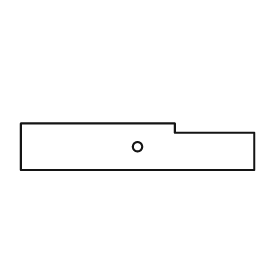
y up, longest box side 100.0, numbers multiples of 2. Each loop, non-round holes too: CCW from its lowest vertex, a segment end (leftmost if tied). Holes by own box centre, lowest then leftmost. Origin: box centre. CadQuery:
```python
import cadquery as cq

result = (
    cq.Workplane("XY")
    .moveTo(-50.0, -10.0)
    .lineTo(50.0, -10.0)
    .lineTo(50.0, 6.0)
    .lineTo(16.0, 6.0)
    .lineTo(16.0, 10.0)
    .lineTo(-50.0, 10.0)
    .close()
    .moveTo(0.0, 0.0)
    .circle(2.0)
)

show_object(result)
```